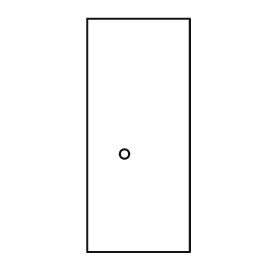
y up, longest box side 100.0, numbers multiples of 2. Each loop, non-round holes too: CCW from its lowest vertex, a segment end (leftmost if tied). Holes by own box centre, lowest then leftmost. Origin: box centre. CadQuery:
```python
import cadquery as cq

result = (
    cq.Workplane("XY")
    .moveTo(-22.0, -50.0)
    .lineTo(22.0, -50.0)
    .lineTo(22.0, 50.0)
    .lineTo(-22.0, 50.0)
    .close()
    .moveTo(-6.0, -8.0)
    .circle(2.0)
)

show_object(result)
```